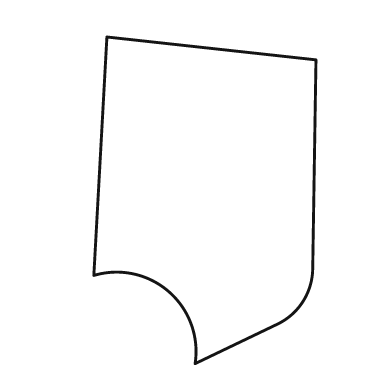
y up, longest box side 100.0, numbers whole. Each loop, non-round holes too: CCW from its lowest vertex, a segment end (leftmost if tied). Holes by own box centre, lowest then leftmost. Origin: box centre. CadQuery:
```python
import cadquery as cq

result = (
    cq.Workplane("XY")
    .moveTo(-3.0, -50.0)
    .lineTo(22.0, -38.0)
    .threePointArc((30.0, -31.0), (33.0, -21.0))
    .lineTo(34.0, 43.0)
    .lineTo(-30.0, 50.0)
    .lineTo(-34.0, -23.0)
    .threePointArc((-11.0, -28.0), (-3.0, -50.0))
    .close()
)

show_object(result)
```